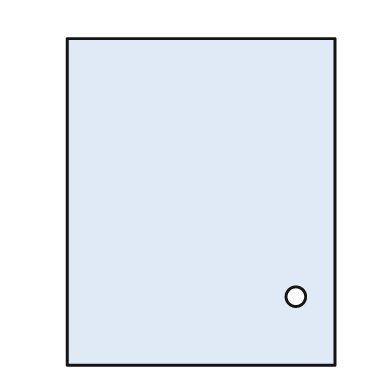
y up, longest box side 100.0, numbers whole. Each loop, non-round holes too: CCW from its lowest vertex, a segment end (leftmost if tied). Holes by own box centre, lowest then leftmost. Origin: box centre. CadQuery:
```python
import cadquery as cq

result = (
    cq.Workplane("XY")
    .moveTo(-41.0, -50.0)
    .lineTo(41.0, -50.0)
    .lineTo(41.0, 50.0)
    .lineTo(-41.0, 50.0)
    .close()
    .moveTo(29.0, -29.0)
    .circle(3.0)
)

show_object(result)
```